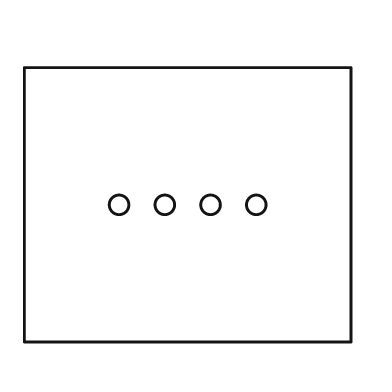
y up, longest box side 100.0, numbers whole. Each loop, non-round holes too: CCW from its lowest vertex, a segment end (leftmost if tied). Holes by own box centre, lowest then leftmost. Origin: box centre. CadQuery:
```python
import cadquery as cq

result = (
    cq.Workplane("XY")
    .moveTo(-50.0, -42.0)
    .lineTo(50.0, -42.0)
    .lineTo(50.0, 42.0)
    .lineTo(-50.0, 42.0)
    .close()
    .moveTo(-21.0, 0.0)
    .circle(3.0)
    .moveTo(-7.0, 0.0)
    .circle(3.0)
    .moveTo(7.0, 0.0)
    .circle(3.0)
    .moveTo(21.0, 0.0)
    .circle(3.0)
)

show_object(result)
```